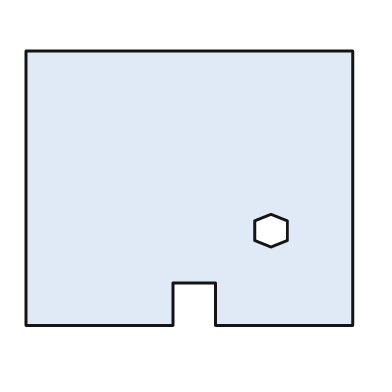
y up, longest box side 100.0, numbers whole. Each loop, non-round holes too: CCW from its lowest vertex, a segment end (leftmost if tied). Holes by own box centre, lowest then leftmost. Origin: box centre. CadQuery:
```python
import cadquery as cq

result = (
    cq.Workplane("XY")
    .moveTo(-50.0, -42.0)
    .lineTo(-5.0, -42.0)
    .lineTo(-5.0, -29.0)
    .lineTo(8.0, -29.0)
    .lineTo(8.0, -42.0)
    .lineTo(50.0, -42.0)
    .lineTo(50.0, 42.0)
    .lineTo(-50.0, 42.0)
    .close()
    .moveTo(25.0, -18.0)
    .lineTo(30.0, -16.0)
    .lineTo(30.0, -10.0)
    .lineTo(25.0, -8.0)
    .lineTo(20.0, -10.0)
    .lineTo(20.0, -16.0)
    .close()
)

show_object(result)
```